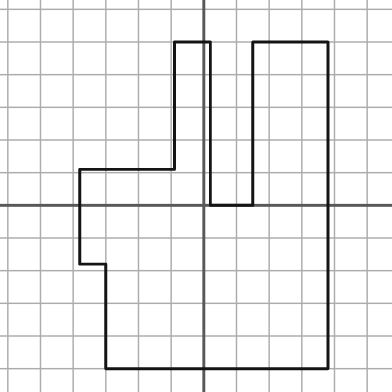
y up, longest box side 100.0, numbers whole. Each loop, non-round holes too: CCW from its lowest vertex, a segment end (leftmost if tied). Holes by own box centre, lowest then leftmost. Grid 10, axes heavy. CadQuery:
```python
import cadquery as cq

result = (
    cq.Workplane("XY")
    .moveTo(-30.0, -50.0)
    .lineTo(38.0, -50.0)
    .lineTo(38.0, 50.0)
    .lineTo(15.0, 50.0)
    .lineTo(15.0, 0.0)
    .lineTo(2.0, 0.0)
    .lineTo(2.0, 50.0)
    .lineTo(-9.0, 50.0)
    .lineTo(-9.0, 11.0)
    .lineTo(-38.0, 11.0)
    .lineTo(-38.0, -18.0)
    .lineTo(-30.0, -18.0)
    .close()
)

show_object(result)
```